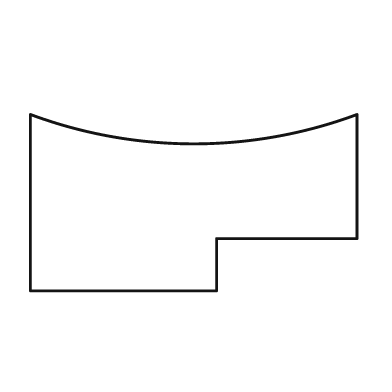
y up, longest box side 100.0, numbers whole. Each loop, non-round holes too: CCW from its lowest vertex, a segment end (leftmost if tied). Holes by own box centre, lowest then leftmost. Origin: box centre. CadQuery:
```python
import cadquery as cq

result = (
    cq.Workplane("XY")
    .moveTo(-50.0, -27.0)
    .lineTo(7.0, -27.0)
    .lineTo(7.0, -11.0)
    .lineTo(50.0, -11.0)
    .lineTo(50.0, 27.0)
    .threePointArc((0.0, 18.0), (-50.0, 27.0))
    .close()
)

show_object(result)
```